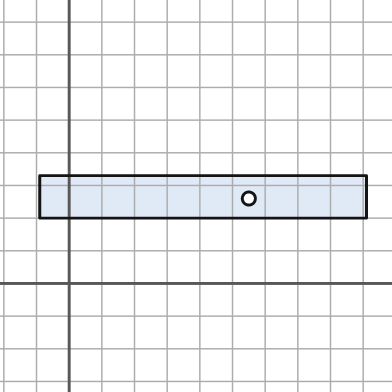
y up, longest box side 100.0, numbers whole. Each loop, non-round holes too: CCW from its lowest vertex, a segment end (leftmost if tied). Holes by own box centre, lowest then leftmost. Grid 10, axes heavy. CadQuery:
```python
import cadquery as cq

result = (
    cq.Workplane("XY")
    .moveTo(-9.0, 20.0)
    .lineTo(91.0, 20.0)
    .lineTo(91.0, 33.0)
    .lineTo(-9.0, 33.0)
    .close()
    .moveTo(55.0, 26.0)
    .circle(2.0)
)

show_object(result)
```